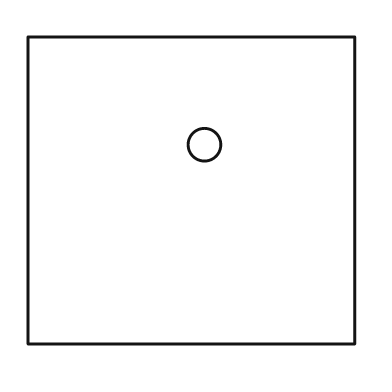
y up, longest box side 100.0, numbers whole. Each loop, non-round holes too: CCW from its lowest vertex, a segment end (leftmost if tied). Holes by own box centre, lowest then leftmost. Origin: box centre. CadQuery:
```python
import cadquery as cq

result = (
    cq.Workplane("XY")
    .moveTo(-50.0, -47.0)
    .lineTo(50.0, -47.0)
    .lineTo(50.0, 47.0)
    .lineTo(-50.0, 47.0)
    .close()
    .moveTo(4.0, 14.0)
    .circle(5.0)
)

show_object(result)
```